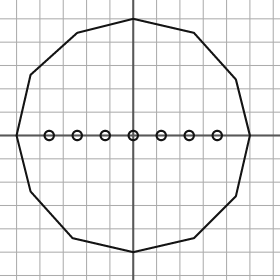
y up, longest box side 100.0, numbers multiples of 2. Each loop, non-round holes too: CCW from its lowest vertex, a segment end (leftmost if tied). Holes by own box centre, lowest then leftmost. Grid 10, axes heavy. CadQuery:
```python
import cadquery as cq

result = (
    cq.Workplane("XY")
    .moveTo(0.0, -50.0)
    .lineTo(26.0, -44.0)
    .lineTo(44.0, -26.0)
    .lineTo(50.0, 0.0)
    .lineTo(44.0, 24.0)
    .lineTo(26.0, 44.0)
    .lineTo(0.0, 50.0)
    .lineTo(-24.0, 44.0)
    .lineTo(-44.0, 26.0)
    .lineTo(-50.0, 0.0)
    .lineTo(-44.0, -24.0)
    .lineTo(-26.0, -44.0)
    .close()
    .moveTo(-36.0, 0.0)
    .circle(2.0)
    .moveTo(-24.0, 0.0)
    .circle(2.0)
    .moveTo(-12.0, 0.0)
    .circle(2.0)
    .moveTo(0.0, 0.0)
    .circle(2.0)
    .moveTo(12.0, 0.0)
    .circle(2.0)
    .moveTo(24.0, 0.0)
    .circle(2.0)
    .moveTo(36.0, 0.0)
    .circle(2.0)
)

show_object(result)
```